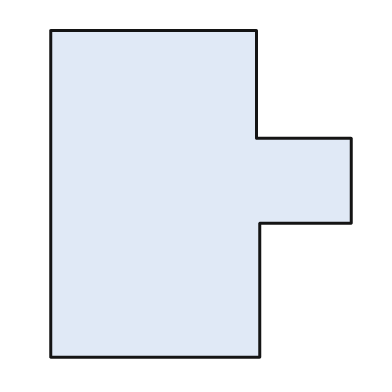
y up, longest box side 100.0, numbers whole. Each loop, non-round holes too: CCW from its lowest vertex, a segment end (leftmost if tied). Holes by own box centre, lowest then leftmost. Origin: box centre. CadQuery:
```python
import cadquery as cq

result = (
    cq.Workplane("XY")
    .moveTo(-46.0, -50.0)
    .lineTo(18.0, -50.0)
    .lineTo(18.0, -9.0)
    .lineTo(46.0, -9.0)
    .lineTo(46.0, 17.0)
    .lineTo(17.0, 17.0)
    .lineTo(17.0, 50.0)
    .lineTo(-46.0, 50.0)
    .close()
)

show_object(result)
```